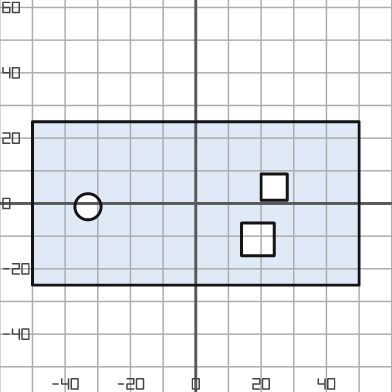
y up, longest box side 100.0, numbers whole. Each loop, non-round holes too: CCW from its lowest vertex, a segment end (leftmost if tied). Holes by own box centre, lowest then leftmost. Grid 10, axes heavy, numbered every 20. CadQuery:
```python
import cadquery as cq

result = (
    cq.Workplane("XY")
    .moveTo(-50.0, -25.0)
    .lineTo(50.0, -25.0)
    .lineTo(50.0, 25.0)
    .lineTo(-50.0, 25.0)
    .close()
    .moveTo(14.0, -16.0)
    .lineTo(24.0, -16.0)
    .lineTo(24.0, -6.0)
    .lineTo(14.0, -6.0)
    .close()
    .moveTo(-33.0, -1.0)
    .circle(4.0)
    .moveTo(20.0, 1.0)
    .lineTo(28.0, 1.0)
    .lineTo(28.0, 9.0)
    .lineTo(20.0, 9.0)
    .close()
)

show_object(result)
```